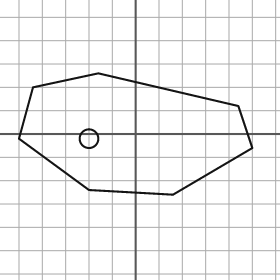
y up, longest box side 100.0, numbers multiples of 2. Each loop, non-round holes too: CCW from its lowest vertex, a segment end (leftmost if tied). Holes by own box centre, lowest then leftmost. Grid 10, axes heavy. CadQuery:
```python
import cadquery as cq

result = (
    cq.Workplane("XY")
    .moveTo(16.0, -26.0)
    .lineTo(50.0, -6.0)
    .lineTo(44.0, 12.0)
    .lineTo(-16.0, 26.0)
    .lineTo(-44.0, 20.0)
    .lineTo(-50.0, -2.0)
    .lineTo(-20.0, -24.0)
    .close()
    .moveTo(-20.0, -2.0)
    .circle(4.0)
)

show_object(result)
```